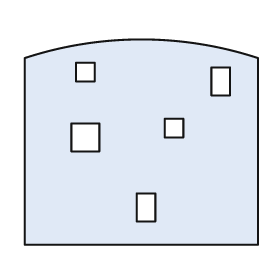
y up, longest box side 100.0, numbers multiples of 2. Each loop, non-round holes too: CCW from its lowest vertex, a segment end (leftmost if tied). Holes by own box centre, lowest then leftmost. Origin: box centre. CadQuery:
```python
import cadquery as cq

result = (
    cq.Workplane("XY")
    .moveTo(-50.0, -44.0)
    .lineTo(50.0, -44.0)
    .lineTo(50.0, 36.0)
    .threePointArc((0.0, 44.0), (-50.0, 36.0))
    .close()
    .moveTo(-2.0, -34.0)
    .lineTo(6.0, -34.0)
    .lineTo(6.0, -22.0)
    .lineTo(-2.0, -22.0)
    .close()
    .moveTo(-30.0, -4.0)
    .lineTo(-18.0, -4.0)
    .lineTo(-18.0, 8.0)
    .lineTo(-30.0, 8.0)
    .close()
    .moveTo(10.0, 2.0)
    .lineTo(18.0, 2.0)
    .lineTo(18.0, 10.0)
    .lineTo(10.0, 10.0)
    .close()
    .moveTo(30.0, 20.0)
    .lineTo(38.0, 20.0)
    .lineTo(38.0, 32.0)
    .lineTo(30.0, 32.0)
    .close()
    .moveTo(-28.0, 26.0)
    .lineTo(-20.0, 26.0)
    .lineTo(-20.0, 34.0)
    .lineTo(-28.0, 34.0)
    .close()
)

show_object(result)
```